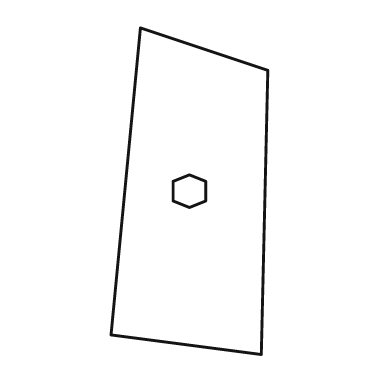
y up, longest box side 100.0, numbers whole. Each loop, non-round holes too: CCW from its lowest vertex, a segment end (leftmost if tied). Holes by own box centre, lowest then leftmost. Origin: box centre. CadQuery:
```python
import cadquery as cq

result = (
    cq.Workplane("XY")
    .moveTo(22.0, -50.0)
    .lineTo(24.0, 37.0)
    .lineTo(-15.0, 50.0)
    .lineTo(-24.0, -44.0)
    .close()
    .moveTo(0.0, -5.0)
    .lineTo(5.0, -3.0)
    .lineTo(5.0, 3.0)
    .lineTo(0.0, 5.0)
    .lineTo(-5.0, 3.0)
    .lineTo(-5.0, -3.0)
    .close()
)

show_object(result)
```